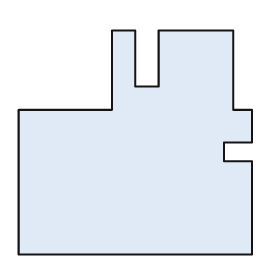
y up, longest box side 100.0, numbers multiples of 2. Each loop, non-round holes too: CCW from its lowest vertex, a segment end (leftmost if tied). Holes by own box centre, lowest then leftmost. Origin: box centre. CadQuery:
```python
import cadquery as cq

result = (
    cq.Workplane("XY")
    .moveTo(-50.0, -48.0)
    .lineTo(50.0, -48.0)
    .lineTo(50.0, -8.0)
    .lineTo(38.0, -8.0)
    .lineTo(38.0, 0.0)
    .lineTo(50.0, 0.0)
    .lineTo(50.0, 14.0)
    .lineTo(42.0, 14.0)
    .lineTo(42.0, 48.0)
    .lineTo(10.0, 48.0)
    .lineTo(10.0, 24.0)
    .lineTo(0.0, 24.0)
    .lineTo(0.0, 48.0)
    .lineTo(-10.0, 48.0)
    .lineTo(-10.0, 14.0)
    .lineTo(-50.0, 14.0)
    .close()
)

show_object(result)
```